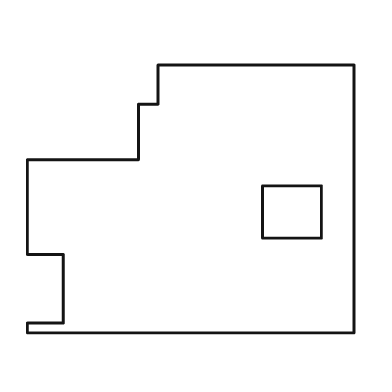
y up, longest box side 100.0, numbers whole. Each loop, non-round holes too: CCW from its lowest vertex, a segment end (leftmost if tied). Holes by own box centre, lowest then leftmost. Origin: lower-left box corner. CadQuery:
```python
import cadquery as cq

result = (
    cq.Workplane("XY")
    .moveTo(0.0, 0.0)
    .lineTo(100.0, 0.0)
    .lineTo(100.0, 82.0)
    .lineTo(40.0, 82.0)
    .lineTo(40.0, 70.0)
    .lineTo(34.0, 70.0)
    .lineTo(34.0, 53.0)
    .lineTo(0.0, 53.0)
    .lineTo(0.0, 24.0)
    .lineTo(11.0, 24.0)
    .lineTo(11.0, 3.0)
    .lineTo(0.0, 3.0)
    .close()
    .moveTo(72.0, 29.0)
    .lineTo(90.0, 29.0)
    .lineTo(90.0, 45.0)
    .lineTo(72.0, 45.0)
    .close()
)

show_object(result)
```